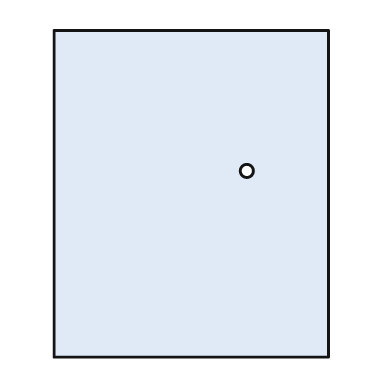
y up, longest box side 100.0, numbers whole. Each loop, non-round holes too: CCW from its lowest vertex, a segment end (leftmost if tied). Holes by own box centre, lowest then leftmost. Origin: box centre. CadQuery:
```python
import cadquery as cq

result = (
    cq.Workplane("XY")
    .moveTo(-42.0, -50.0)
    .lineTo(42.0, -50.0)
    .lineTo(42.0, 50.0)
    .lineTo(-42.0, 50.0)
    .close()
    .moveTo(17.0, 7.0)
    .circle(2.0)
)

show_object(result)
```